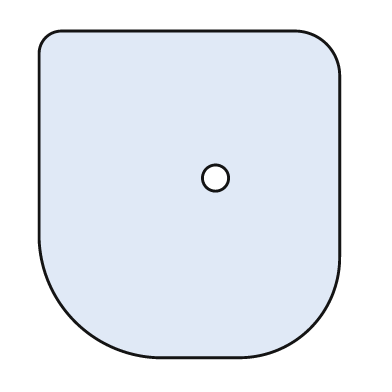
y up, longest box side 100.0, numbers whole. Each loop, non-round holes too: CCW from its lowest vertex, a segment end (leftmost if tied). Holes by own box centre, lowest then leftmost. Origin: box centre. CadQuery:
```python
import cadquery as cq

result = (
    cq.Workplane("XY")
    .moveTo(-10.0, -50.0)
    .lineTo(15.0, -50.0)
    .threePointArc((37.0, -41.0), (46.0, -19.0))
    .lineTo(46.0, 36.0)
    .threePointArc((42.0, 46.0), (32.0, 50.0))
    .lineTo(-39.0, 50.0)
    .threePointArc((-44.0, 48.0), (-46.0, 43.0))
    .lineTo(-46.0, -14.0)
    .threePointArc((-35.0, -39.0), (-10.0, -50.0))
    .close()
    .moveTo(8.0, 5.0)
    .circle(4.0)
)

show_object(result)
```